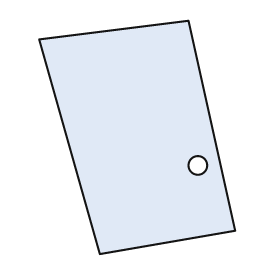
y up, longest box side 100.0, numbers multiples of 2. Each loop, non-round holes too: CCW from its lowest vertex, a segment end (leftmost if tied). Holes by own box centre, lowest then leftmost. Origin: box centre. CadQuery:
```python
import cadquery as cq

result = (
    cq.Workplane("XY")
    .moveTo(-16.0, -50.0)
    .lineTo(42.0, -40.0)
    .lineTo(22.0, 50.0)
    .lineTo(-42.0, 42.0)
    .close()
    .moveTo(26.0, -12.0)
    .circle(4.0)
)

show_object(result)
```